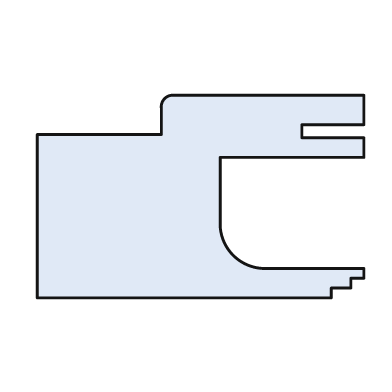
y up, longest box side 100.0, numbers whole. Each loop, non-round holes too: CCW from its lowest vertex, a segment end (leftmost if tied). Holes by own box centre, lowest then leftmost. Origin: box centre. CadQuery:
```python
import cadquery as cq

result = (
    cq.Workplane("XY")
    .moveTo(-50.0, -31.0)
    .lineTo(40.0, -31.0)
    .lineTo(40.0, -28.0)
    .lineTo(46.0, -28.0)
    .lineTo(46.0, -25.0)
    .lineTo(50.0, -25.0)
    .lineTo(50.0, -22.0)
    .lineTo(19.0, -22.0)
    .threePointArc((10.0, -18.0), (6.0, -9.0))
    .lineTo(6.0, 12.0)
    .lineTo(50.0, 12.0)
    .lineTo(50.0, 18.0)
    .lineTo(31.0, 18.0)
    .lineTo(31.0, 22.0)
    .lineTo(50.0, 22.0)
    .lineTo(50.0, 31.0)
    .lineTo(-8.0, 31.0)
    .threePointArc((-11.0, 30.0), (-12.0, 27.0))
    .lineTo(-12.0, 19.0)
    .lineTo(-50.0, 19.0)
    .close()
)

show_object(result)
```